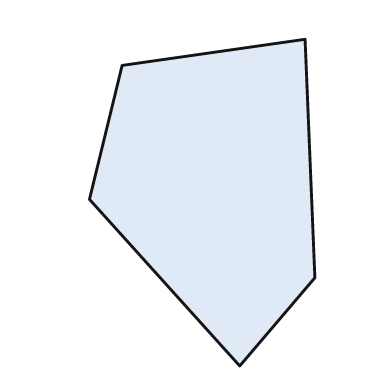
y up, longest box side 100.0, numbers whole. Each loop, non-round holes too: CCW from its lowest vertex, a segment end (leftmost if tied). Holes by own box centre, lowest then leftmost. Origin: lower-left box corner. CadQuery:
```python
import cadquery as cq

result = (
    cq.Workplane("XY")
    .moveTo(46.0, 0.0)
    .lineTo(69.0, 27.0)
    .lineTo(66.0, 100.0)
    .lineTo(10.0, 92.0)
    .lineTo(0.0, 51.0)
    .close()
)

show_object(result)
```